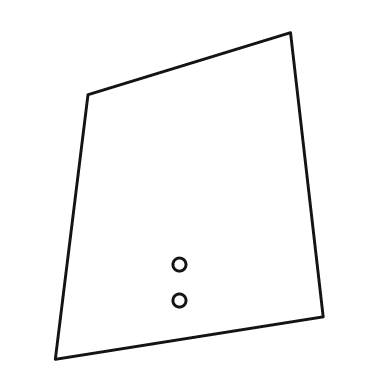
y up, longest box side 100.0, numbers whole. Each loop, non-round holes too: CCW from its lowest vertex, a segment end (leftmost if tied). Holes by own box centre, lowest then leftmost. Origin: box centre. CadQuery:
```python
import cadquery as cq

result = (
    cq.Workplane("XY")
    .moveTo(-41.0, -50.0)
    .lineTo(41.0, -37.0)
    .lineTo(31.0, 50.0)
    .lineTo(-31.0, 31.0)
    .close()
    .moveTo(-3.0, -32.0)
    .circle(2.0)
    .moveTo(-3.0, -21.0)
    .circle(2.0)
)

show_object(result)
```